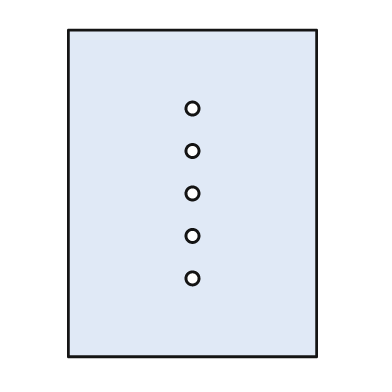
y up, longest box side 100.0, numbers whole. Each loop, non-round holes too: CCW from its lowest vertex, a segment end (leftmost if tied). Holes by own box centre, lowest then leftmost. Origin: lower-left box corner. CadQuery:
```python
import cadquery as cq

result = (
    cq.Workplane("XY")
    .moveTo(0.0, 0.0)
    .lineTo(76.0, 0.0)
    .lineTo(76.0, 100.0)
    .lineTo(0.0, 100.0)
    .close()
    .moveTo(38.0, 24.0)
    .circle(2.0)
    .moveTo(38.0, 37.0)
    .circle(2.0)
    .moveTo(38.0, 50.0)
    .circle(2.0)
    .moveTo(38.0, 63.0)
    .circle(2.0)
    .moveTo(38.0, 76.0)
    .circle(2.0)
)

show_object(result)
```